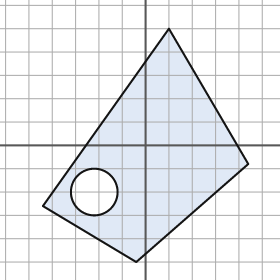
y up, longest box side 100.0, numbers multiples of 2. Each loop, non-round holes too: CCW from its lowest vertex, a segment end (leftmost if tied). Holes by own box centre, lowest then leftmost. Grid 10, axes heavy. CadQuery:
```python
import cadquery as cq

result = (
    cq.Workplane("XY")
    .moveTo(-4.0, -50.0)
    .lineTo(44.0, -8.0)
    .lineTo(10.0, 50.0)
    .lineTo(-44.0, -26.0)
    .close()
    .moveTo(-22.0, -20.0)
    .circle(10.0)
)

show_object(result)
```